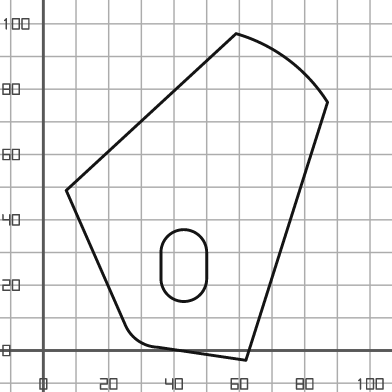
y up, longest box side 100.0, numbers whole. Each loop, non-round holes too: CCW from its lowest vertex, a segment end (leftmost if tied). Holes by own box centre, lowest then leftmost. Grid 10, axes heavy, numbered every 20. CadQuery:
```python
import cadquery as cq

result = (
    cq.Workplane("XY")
    .moveTo(62.0, -3.0)
    .lineTo(87.0, 76.0)
    .threePointArc((75.0, 89.0), (59.0, 97.0))
    .lineTo(7.0, 49.0)
    .lineTo(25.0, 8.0)
    .threePointArc((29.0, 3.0), (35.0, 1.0))
    .close()
    .moveTo(36.0, 22.0)
    .threePointArc((43.0, 15.0), (50.0, 22.0))
    .lineTo(50.0, 30.0)
    .threePointArc((43.0, 37.0), (36.0, 30.0))
    .close()
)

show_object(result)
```